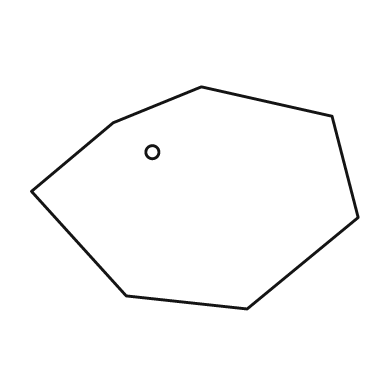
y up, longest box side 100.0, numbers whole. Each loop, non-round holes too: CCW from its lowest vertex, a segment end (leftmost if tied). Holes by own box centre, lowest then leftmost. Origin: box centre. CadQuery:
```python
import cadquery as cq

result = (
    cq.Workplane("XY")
    .moveTo(16.0, -34.0)
    .lineTo(50.0, -6.0)
    .lineTo(42.0, 25.0)
    .lineTo(2.0, 34.0)
    .lineTo(-25.0, 23.0)
    .lineTo(-50.0, 2.0)
    .lineTo(-21.0, -30.0)
    .close()
    .moveTo(-13.0, 14.0)
    .circle(2.0)
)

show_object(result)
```